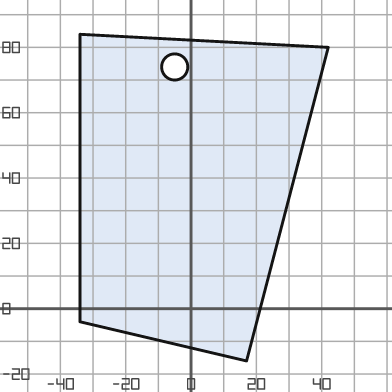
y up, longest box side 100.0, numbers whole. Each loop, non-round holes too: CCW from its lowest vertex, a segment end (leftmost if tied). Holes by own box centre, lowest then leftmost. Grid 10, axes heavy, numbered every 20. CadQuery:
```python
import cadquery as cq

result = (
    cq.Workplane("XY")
    .moveTo(17.0, -16.0)
    .lineTo(42.0, 80.0)
    .lineTo(-34.0, 84.0)
    .lineTo(-34.0, -4.0)
    .close()
    .moveTo(-5.0, 74.0)
    .circle(4.0)
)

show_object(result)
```